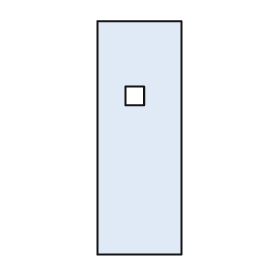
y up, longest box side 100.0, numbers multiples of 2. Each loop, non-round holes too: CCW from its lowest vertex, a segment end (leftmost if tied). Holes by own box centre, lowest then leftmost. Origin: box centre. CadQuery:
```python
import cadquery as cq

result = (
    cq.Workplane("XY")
    .moveTo(-18.0, -50.0)
    .lineTo(18.0, -50.0)
    .lineTo(18.0, 50.0)
    .lineTo(-18.0, 50.0)
    .close()
    .moveTo(-6.0, 14.0)
    .lineTo(2.0, 14.0)
    .lineTo(2.0, 22.0)
    .lineTo(-6.0, 22.0)
    .close()
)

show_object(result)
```